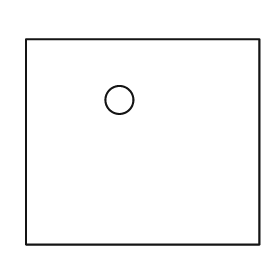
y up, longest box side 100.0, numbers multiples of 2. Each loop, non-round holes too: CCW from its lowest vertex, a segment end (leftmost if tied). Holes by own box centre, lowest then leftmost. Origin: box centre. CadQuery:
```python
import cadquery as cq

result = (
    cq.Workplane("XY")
    .moveTo(-50.0, -44.0)
    .lineTo(50.0, -44.0)
    .lineTo(50.0, 44.0)
    .lineTo(-50.0, 44.0)
    .close()
    .moveTo(-10.0, 18.0)
    .circle(6.0)
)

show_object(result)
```